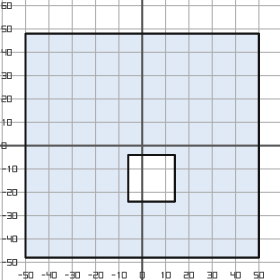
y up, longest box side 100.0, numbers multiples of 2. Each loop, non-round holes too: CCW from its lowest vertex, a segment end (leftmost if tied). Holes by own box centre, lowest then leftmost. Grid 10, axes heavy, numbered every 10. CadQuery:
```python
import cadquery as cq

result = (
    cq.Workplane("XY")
    .moveTo(-50.0, -48.0)
    .lineTo(50.0, -48.0)
    .lineTo(50.0, 48.0)
    .lineTo(-50.0, 48.0)
    .close()
    .moveTo(-6.0, -24.0)
    .lineTo(14.0, -24.0)
    .lineTo(14.0, -4.0)
    .lineTo(-6.0, -4.0)
    .close()
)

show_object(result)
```